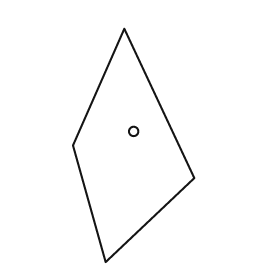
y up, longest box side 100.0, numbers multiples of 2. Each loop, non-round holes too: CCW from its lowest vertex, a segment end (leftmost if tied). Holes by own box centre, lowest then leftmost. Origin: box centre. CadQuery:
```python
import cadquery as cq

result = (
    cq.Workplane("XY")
    .moveTo(-12.0, -50.0)
    .lineTo(26.0, -14.0)
    .lineTo(-4.0, 50.0)
    .lineTo(-26.0, 0.0)
    .close()
    .moveTo(0.0, 6.0)
    .circle(2.0)
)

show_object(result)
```